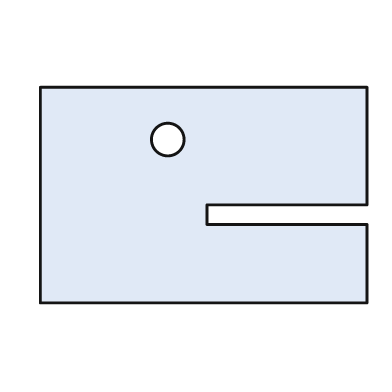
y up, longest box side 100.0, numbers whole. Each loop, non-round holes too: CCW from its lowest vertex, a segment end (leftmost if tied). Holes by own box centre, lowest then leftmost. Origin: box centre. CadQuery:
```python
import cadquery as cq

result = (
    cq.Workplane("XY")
    .moveTo(-50.0, -33.0)
    .lineTo(50.0, -33.0)
    .lineTo(50.0, -9.0)
    .lineTo(1.0, -9.0)
    .lineTo(1.0, -3.0)
    .lineTo(50.0, -3.0)
    .lineTo(50.0, 33.0)
    .lineTo(-50.0, 33.0)
    .close()
    .moveTo(-11.0, 17.0)
    .circle(5.0)
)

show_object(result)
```